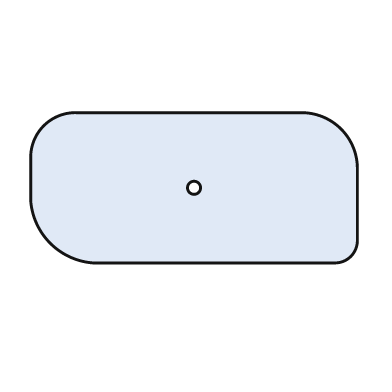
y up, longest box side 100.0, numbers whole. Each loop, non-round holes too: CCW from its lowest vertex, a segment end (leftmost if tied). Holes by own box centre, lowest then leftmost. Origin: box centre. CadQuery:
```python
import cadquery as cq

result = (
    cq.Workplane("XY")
    .moveTo(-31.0, -23.0)
    .lineTo(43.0, -23.0)
    .threePointArc((48.0, -21.0), (50.0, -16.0))
    .lineTo(50.0, 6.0)
    .threePointArc((45.0, 18.0), (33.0, 23.0))
    .lineTo(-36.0, 23.0)
    .threePointArc((-46.0, 19.0), (-50.0, 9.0))
    .lineTo(-50.0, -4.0)
    .threePointArc((-44.0, -17.0), (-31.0, -23.0))
    .close()
    .moveTo(0.0, 0.0)
    .circle(2.0)
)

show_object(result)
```